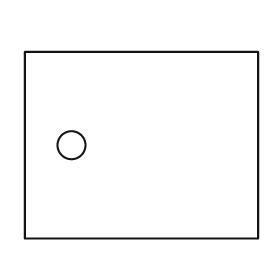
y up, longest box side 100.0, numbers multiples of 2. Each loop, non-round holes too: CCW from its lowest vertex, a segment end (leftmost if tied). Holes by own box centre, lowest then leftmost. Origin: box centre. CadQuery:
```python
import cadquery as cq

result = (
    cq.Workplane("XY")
    .moveTo(-50.0, -40.0)
    .lineTo(50.0, -40.0)
    .lineTo(50.0, 40.0)
    .lineTo(-50.0, 40.0)
    .close()
    .moveTo(-30.0, 0.0)
    .circle(6.0)
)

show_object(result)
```